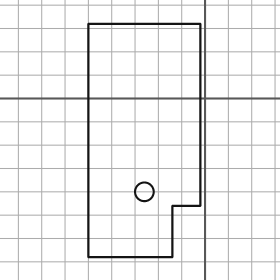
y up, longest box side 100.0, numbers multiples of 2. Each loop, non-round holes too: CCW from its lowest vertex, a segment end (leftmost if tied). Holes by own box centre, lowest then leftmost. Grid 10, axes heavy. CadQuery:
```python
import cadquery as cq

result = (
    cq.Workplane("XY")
    .moveTo(-50.0, -68.0)
    .lineTo(-14.0, -68.0)
    .lineTo(-14.0, -46.0)
    .lineTo(-2.0, -46.0)
    .lineTo(-2.0, 32.0)
    .lineTo(-50.0, 32.0)
    .close()
    .moveTo(-26.0, -40.0)
    .circle(4.0)
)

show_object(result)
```